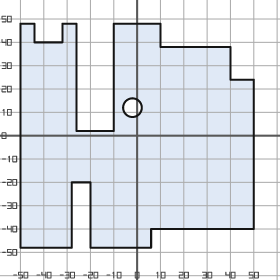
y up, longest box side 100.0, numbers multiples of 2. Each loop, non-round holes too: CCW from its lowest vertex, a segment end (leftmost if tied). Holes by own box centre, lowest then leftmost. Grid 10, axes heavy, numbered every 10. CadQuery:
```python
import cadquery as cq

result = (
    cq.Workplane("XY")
    .moveTo(-50.0, -48.0)
    .lineTo(-28.0, -48.0)
    .lineTo(-28.0, -20.0)
    .lineTo(-20.0, -20.0)
    .lineTo(-20.0, -48.0)
    .lineTo(6.0, -48.0)
    .lineTo(6.0, -40.0)
    .lineTo(50.0, -40.0)
    .lineTo(50.0, 24.0)
    .lineTo(40.0, 24.0)
    .lineTo(40.0, 38.0)
    .lineTo(10.0, 38.0)
    .lineTo(10.0, 48.0)
    .lineTo(-10.0, 48.0)
    .lineTo(-10.0, 2.0)
    .lineTo(-26.0, 2.0)
    .lineTo(-26.0, 48.0)
    .lineTo(-32.0, 48.0)
    .lineTo(-32.0, 40.0)
    .lineTo(-44.0, 40.0)
    .lineTo(-44.0, 48.0)
    .lineTo(-50.0, 48.0)
    .close()
    .moveTo(-2.0, 12.0)
    .circle(4.0)
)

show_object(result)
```